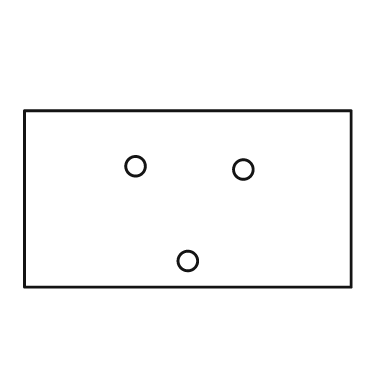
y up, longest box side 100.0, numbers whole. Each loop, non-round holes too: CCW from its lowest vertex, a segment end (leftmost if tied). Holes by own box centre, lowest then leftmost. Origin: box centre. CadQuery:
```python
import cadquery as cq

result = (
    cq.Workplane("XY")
    .moveTo(-50.0, -27.0)
    .lineTo(50.0, -27.0)
    .lineTo(50.0, 27.0)
    .lineTo(-50.0, 27.0)
    .close()
    .moveTo(0.0, -19.0)
    .circle(3.0)
    .moveTo(17.0, 9.0)
    .circle(3.0)
    .moveTo(-16.0, 10.0)
    .circle(3.0)
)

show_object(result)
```